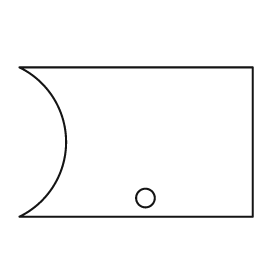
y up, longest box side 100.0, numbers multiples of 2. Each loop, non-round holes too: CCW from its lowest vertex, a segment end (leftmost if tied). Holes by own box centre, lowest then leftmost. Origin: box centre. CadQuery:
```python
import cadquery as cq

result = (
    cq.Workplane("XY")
    .moveTo(-50.0, -32.0)
    .lineTo(50.0, -32.0)
    .lineTo(50.0, 32.0)
    .lineTo(-50.0, 32.0)
    .threePointArc((-30.0, 0.0), (-50.0, -32.0))
    .close()
    .moveTo(4.0, -24.0)
    .circle(4.0)
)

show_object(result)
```